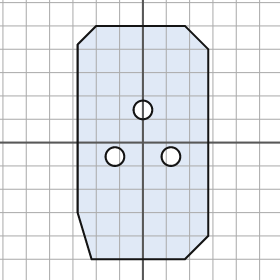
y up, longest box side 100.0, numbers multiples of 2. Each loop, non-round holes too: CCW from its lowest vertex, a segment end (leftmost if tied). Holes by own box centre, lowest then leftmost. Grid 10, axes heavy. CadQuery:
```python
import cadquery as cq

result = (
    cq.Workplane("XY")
    .moveTo(-22.0, -50.0)
    .lineTo(18.0, -50.0)
    .lineTo(28.0, -40.0)
    .lineTo(28.0, 40.0)
    .lineTo(18.0, 50.0)
    .lineTo(-20.0, 50.0)
    .lineTo(-28.0, 42.0)
    .lineTo(-28.0, -30.0)
    .close()
    .moveTo(-12.0, -6.0)
    .circle(4.0)
    .moveTo(12.0, -6.0)
    .circle(4.0)
    .moveTo(0.0, 14.0)
    .circle(4.0)
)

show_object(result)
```